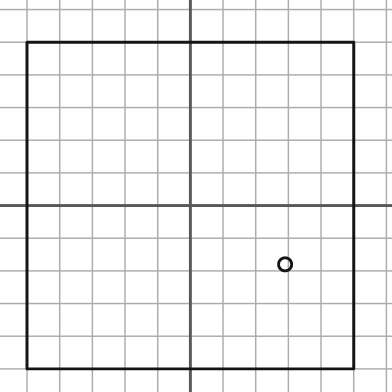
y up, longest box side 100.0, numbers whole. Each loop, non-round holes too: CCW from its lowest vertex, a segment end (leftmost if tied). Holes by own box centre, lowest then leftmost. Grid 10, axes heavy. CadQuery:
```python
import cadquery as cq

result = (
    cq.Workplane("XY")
    .moveTo(-50.0, -50.0)
    .lineTo(50.0, -50.0)
    .lineTo(50.0, 50.0)
    .lineTo(-50.0, 50.0)
    .close()
    .moveTo(29.0, -18.0)
    .circle(2.0)
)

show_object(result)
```